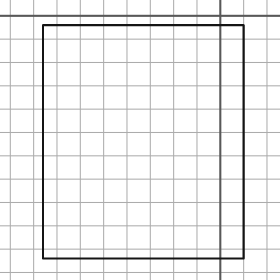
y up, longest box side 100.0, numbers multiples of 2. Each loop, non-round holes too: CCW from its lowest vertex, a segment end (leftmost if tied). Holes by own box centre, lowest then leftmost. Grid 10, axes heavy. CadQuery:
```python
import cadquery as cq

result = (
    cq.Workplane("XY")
    .moveTo(-76.0, -104.0)
    .lineTo(10.0, -104.0)
    .lineTo(10.0, -4.0)
    .lineTo(-76.0, -4.0)
    .close()
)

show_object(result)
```